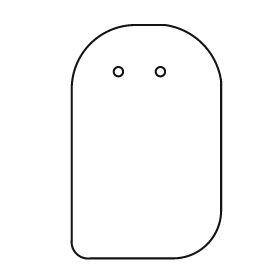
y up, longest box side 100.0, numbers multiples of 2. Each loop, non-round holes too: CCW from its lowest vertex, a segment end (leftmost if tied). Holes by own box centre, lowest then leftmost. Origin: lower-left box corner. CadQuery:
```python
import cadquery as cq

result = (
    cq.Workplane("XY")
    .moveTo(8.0, 0.0)
    .lineTo(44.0, 0.0)
    .threePointArc((58.0, 6.0), (64.0, 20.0))
    .lineTo(64.0, 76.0)
    .threePointArc((56.0, 92.0), (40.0, 100.0))
    .lineTo(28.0, 100.0)
    .threePointArc((8.0, 92.0), (0.0, 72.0))
    .lineTo(0.0, 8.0)
    .threePointArc((2.0, 2.0), (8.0, 0.0))
    .close()
    .moveTo(20.0, 80.0)
    .circle(2.0)
    .moveTo(38.0, 80.0)
    .circle(2.0)
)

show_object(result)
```